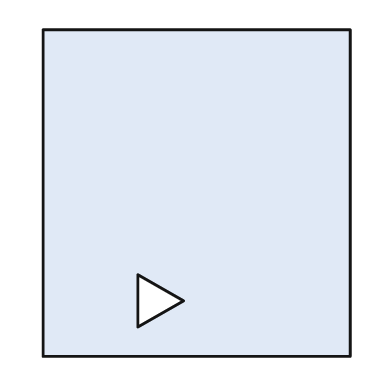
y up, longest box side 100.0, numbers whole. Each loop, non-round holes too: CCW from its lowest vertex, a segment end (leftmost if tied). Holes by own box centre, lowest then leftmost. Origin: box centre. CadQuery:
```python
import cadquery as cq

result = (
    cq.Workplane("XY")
    .moveTo(-47.0, -50.0)
    .lineTo(47.0, -50.0)
    .lineTo(47.0, 50.0)
    .lineTo(-47.0, 50.0)
    .close()
    .moveTo(-18.0, -41.0)
    .lineTo(-4.0, -33.0)
    .lineTo(-18.0, -25.0)
    .close()
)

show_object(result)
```